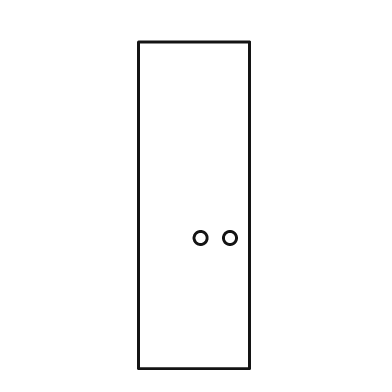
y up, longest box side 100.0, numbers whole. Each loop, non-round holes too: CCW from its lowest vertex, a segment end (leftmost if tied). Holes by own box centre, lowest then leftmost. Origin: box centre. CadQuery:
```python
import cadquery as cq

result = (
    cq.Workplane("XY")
    .moveTo(-17.0, -50.0)
    .lineTo(17.0, -50.0)
    .lineTo(17.0, 50.0)
    .lineTo(-17.0, 50.0)
    .close()
    .moveTo(2.0, -10.0)
    .circle(2.0)
    .moveTo(11.0, -10.0)
    .circle(2.0)
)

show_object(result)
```